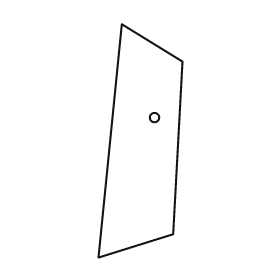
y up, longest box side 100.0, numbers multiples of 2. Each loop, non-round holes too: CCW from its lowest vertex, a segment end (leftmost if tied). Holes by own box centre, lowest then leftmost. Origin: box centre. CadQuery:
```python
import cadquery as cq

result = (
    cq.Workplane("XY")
    .moveTo(-18.0, -50.0)
    .lineTo(14.0, -40.0)
    .lineTo(18.0, 34.0)
    .lineTo(-8.0, 50.0)
    .close()
    .moveTo(6.0, 10.0)
    .circle(2.0)
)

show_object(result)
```